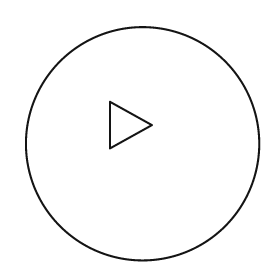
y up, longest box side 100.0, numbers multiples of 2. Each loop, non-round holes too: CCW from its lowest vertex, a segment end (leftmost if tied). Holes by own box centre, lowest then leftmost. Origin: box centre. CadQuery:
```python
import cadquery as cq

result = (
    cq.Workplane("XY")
    .moveTo(0.0, 0.0)
    .circle(50.0)
    .moveTo(-14.0, -2.0)
    .lineTo(4.0, 8.0)
    .lineTo(-14.0, 18.0)
    .close()
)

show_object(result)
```